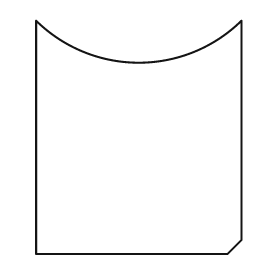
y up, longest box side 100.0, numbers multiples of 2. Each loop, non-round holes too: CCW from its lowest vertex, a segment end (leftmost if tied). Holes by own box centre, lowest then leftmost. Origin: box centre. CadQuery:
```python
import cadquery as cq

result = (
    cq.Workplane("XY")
    .moveTo(-44.0, -50.0)
    .lineTo(38.0, -50.0)
    .lineTo(44.0, -44.0)
    .lineTo(44.0, 50.0)
    .threePointArc((0.0, 32.0), (-44.0, 50.0))
    .close()
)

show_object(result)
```